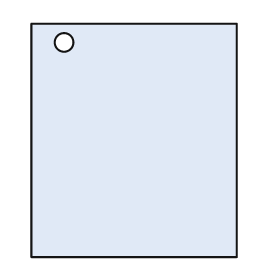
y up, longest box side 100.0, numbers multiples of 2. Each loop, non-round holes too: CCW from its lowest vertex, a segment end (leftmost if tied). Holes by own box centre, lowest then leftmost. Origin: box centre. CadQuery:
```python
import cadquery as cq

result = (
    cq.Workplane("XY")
    .moveTo(-44.0, -50.0)
    .lineTo(44.0, -50.0)
    .lineTo(44.0, 50.0)
    .lineTo(-44.0, 50.0)
    .close()
    .moveTo(-30.0, 42.0)
    .circle(4.0)
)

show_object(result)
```